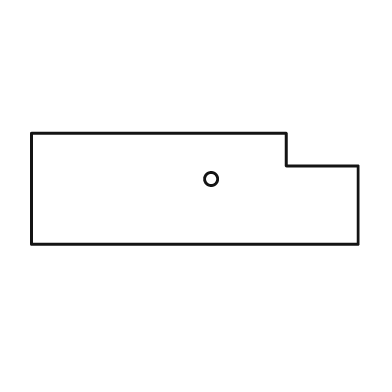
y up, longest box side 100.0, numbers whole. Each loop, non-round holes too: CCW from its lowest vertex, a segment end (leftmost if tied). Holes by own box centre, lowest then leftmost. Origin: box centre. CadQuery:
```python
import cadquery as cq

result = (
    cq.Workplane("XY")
    .moveTo(-50.0, -17.0)
    .lineTo(50.0, -17.0)
    .lineTo(50.0, 7.0)
    .lineTo(28.0, 7.0)
    .lineTo(28.0, 17.0)
    .lineTo(-50.0, 17.0)
    .close()
    .moveTo(5.0, 3.0)
    .circle(2.0)
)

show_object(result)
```